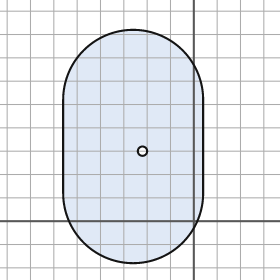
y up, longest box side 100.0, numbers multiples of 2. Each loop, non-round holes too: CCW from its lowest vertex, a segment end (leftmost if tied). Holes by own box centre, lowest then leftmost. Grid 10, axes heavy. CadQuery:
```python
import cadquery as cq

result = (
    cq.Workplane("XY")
    .moveTo(-56.0, 12.0)
    .threePointArc((-26.0, -18.0), (4.0, 12.0))
    .lineTo(4.0, 52.0)
    .threePointArc((-26.0, 82.0), (-56.0, 52.0))
    .close()
    .moveTo(-22.0, 30.0)
    .circle(2.0)
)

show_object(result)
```